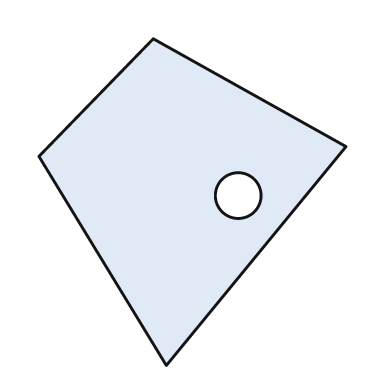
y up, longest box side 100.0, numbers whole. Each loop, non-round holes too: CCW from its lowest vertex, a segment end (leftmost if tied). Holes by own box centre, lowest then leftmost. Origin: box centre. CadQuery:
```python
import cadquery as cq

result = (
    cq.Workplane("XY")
    .moveTo(-8.0, -50.0)
    .lineTo(47.0, 17.0)
    .lineTo(-12.0, 50.0)
    .lineTo(-47.0, 14.0)
    .close()
    .moveTo(14.0, 2.0)
    .circle(7.0)
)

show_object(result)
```